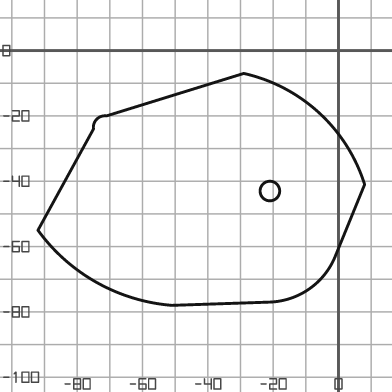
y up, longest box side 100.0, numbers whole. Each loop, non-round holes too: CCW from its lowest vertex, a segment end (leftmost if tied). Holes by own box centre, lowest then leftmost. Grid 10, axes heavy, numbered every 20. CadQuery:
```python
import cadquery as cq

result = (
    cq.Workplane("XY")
    .moveTo(-51.0, -78.0)
    .lineTo(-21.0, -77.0)
    .threePointArc((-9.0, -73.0), (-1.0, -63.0))
    .lineTo(8.0, -41.0)
    .threePointArc((-6.0, -19.0), (-29.0, -7.0))
    .lineTo(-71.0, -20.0)
    .threePointArc((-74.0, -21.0), (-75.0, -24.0))
    .lineTo(-92.0, -55.0)
    .threePointArc((-74.0, -71.0), (-51.0, -78.0))
    .close()
    .moveTo(-21.0, -43.0)
    .circle(3.0)
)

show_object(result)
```